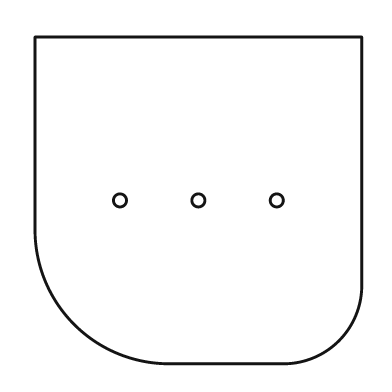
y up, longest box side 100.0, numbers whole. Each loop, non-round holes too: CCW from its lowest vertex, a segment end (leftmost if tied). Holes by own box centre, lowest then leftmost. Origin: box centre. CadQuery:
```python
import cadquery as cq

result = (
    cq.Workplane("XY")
    .moveTo(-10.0, -50.0)
    .lineTo(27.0, -50.0)
    .threePointArc((43.0, -43.0), (50.0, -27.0))
    .lineTo(50.0, 50.0)
    .lineTo(-50.0, 50.0)
    .lineTo(-50.0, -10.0)
    .threePointArc((-38.0, -38.0), (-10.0, -50.0))
    .close()
    .moveTo(-24.0, 0.0)
    .circle(2.0)
    .moveTo(0.0, 0.0)
    .circle(2.0)
    .moveTo(24.0, 0.0)
    .circle(2.0)
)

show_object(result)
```